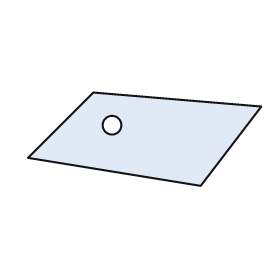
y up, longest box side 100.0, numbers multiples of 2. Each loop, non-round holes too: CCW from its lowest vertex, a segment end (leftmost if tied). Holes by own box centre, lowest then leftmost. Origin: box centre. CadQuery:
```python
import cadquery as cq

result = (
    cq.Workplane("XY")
    .moveTo(24.0, -20.0)
    .lineTo(50.0, 14.0)
    .lineTo(-22.0, 20.0)
    .lineTo(-50.0, -8.0)
    .close()
    .moveTo(-14.0, 6.0)
    .circle(4.0)
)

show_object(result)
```